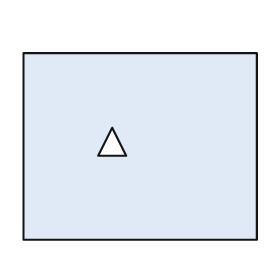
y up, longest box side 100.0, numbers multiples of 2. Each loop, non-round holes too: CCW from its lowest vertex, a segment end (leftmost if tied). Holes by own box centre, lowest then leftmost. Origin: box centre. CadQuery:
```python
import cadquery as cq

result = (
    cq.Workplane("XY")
    .moveTo(-50.0, -40.0)
    .lineTo(50.0, -40.0)
    .lineTo(50.0, 40.0)
    .lineTo(-50.0, 40.0)
    .close()
    .moveTo(-18.0, -4.0)
    .lineTo(-6.0, -4.0)
    .lineTo(-12.0, 8.0)
    .close()
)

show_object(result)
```